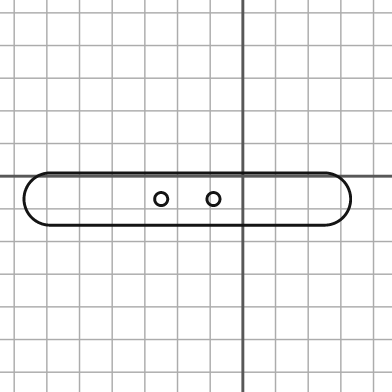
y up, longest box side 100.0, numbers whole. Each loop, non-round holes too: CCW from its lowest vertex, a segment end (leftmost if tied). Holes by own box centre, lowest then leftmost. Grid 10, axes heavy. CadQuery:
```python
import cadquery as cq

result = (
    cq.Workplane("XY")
    .moveTo(-59.0, -15.0)
    .lineTo(25.0, -15.0)
    .threePointArc((33.0, -7.0), (25.0, 1.0))
    .lineTo(-59.0, 1.0)
    .threePointArc((-67.0, -7.0), (-59.0, -15.0))
    .close()
    .moveTo(-25.0, -7.0)
    .circle(2.0)
    .moveTo(-9.0, -7.0)
    .circle(2.0)
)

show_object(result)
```